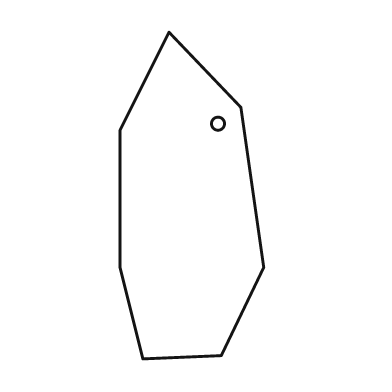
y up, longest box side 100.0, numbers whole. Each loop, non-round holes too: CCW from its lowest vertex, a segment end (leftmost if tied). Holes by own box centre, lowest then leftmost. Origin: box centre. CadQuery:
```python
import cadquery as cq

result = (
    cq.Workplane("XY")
    .moveTo(-15.0, -50.0)
    .lineTo(9.0, -49.0)
    .lineTo(22.0, -22.0)
    .lineTo(15.0, 27.0)
    .lineTo(-7.0, 50.0)
    .lineTo(-22.0, 20.0)
    .lineTo(-22.0, -22.0)
    .close()
    .moveTo(8.0, 22.0)
    .circle(2.0)
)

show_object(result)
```